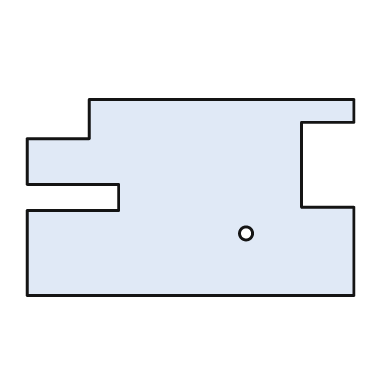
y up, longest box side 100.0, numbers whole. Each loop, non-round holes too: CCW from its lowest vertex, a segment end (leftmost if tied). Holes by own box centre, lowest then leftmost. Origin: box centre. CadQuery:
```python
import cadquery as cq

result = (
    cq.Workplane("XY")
    .moveTo(-50.0, -30.0)
    .lineTo(50.0, -30.0)
    .lineTo(50.0, -3.0)
    .lineTo(34.0, -3.0)
    .lineTo(34.0, 23.0)
    .lineTo(50.0, 23.0)
    .lineTo(50.0, 30.0)
    .lineTo(-31.0, 30.0)
    .lineTo(-31.0, 18.0)
    .lineTo(-50.0, 18.0)
    .lineTo(-50.0, 4.0)
    .lineTo(-22.0, 4.0)
    .lineTo(-22.0, -4.0)
    .lineTo(-50.0, -4.0)
    .close()
    .moveTo(17.0, -11.0)
    .circle(2.0)
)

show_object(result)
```